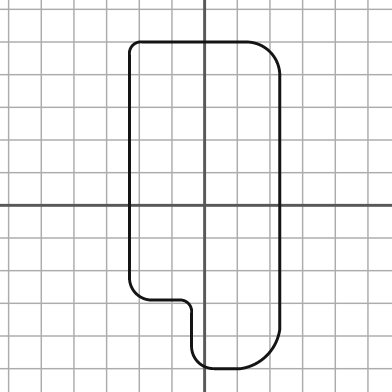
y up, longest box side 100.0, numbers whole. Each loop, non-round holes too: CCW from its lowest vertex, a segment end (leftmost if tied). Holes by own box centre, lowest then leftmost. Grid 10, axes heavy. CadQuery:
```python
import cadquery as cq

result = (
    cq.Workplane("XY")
    .moveTo(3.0, -50.0)
    .lineTo(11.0, -50.0)
    .threePointArc((19.0, -46.0), (23.0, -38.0))
    .lineTo(23.0, 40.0)
    .threePointArc((20.0, 47.0), (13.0, 50.0))
    .lineTo(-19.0, 50.0)
    .threePointArc((-22.0, 49.0), (-23.0, 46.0))
    .lineTo(-23.0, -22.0)
    .threePointArc((-21.0, -27.0), (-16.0, -29.0))
    .lineTo(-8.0, -29.0)
    .threePointArc((-5.0, -30.0), (-4.0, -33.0))
    .lineTo(-4.0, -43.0)
    .threePointArc((-2.0, -48.0), (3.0, -50.0))
    .close()
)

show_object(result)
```